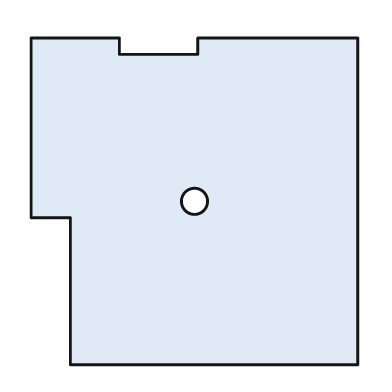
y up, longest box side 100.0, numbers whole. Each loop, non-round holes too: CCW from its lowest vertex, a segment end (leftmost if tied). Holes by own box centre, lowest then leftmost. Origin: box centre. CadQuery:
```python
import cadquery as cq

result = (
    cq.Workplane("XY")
    .moveTo(-38.0, -50.0)
    .lineTo(50.0, -50.0)
    .lineTo(50.0, 50.0)
    .lineTo(1.0, 50.0)
    .lineTo(1.0, 45.0)
    .lineTo(-23.0, 45.0)
    .lineTo(-23.0, 50.0)
    .lineTo(-50.0, 50.0)
    .lineTo(-50.0, -5.0)
    .lineTo(-38.0, -5.0)
    .close()
    .moveTo(0.0, 0.0)
    .circle(4.0)
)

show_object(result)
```